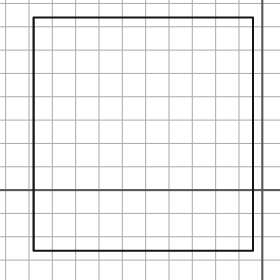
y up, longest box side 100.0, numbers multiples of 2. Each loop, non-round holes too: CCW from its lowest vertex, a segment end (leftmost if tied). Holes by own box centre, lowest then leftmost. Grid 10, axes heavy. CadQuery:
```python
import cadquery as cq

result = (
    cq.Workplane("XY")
    .moveTo(-98.0, -26.0)
    .lineTo(-4.0, -26.0)
    .lineTo(-4.0, 74.0)
    .lineTo(-98.0, 74.0)
    .close()
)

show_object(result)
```